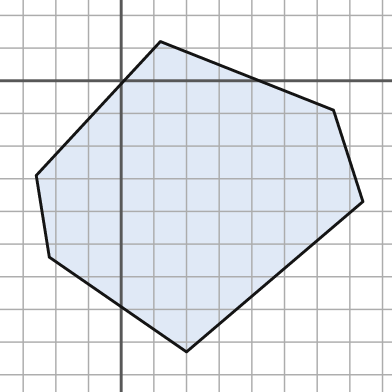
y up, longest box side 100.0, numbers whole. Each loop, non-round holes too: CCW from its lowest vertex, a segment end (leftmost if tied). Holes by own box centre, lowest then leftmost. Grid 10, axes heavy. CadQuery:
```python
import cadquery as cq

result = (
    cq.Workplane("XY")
    .moveTo(20.0, -83.0)
    .lineTo(74.0, -37.0)
    .lineTo(65.0, -9.0)
    .lineTo(12.0, 12.0)
    .lineTo(-26.0, -29.0)
    .lineTo(-22.0, -54.0)
    .close()
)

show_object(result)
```